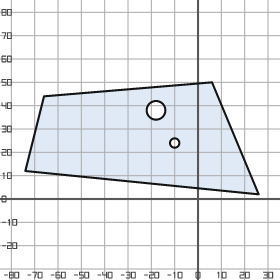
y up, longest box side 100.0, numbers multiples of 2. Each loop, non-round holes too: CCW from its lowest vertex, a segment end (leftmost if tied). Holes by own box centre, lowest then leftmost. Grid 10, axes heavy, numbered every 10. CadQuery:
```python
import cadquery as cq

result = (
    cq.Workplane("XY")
    .moveTo(26.0, 2.0)
    .lineTo(6.0, 50.0)
    .lineTo(-66.0, 44.0)
    .lineTo(-74.0, 12.0)
    .close()
    .moveTo(-10.0, 24.0)
    .circle(2.0)
    .moveTo(-18.0, 38.0)
    .circle(4.0)
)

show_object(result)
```